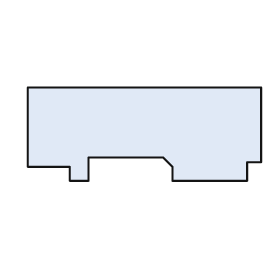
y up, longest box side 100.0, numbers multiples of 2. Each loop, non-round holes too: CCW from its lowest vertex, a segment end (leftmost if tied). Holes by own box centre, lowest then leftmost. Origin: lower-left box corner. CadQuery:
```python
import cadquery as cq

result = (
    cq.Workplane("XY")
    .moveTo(18.0, 0.0)
    .lineTo(26.0, 0.0)
    .lineTo(26.0, 10.0)
    .lineTo(58.0, 10.0)
    .lineTo(62.0, 6.0)
    .lineTo(62.0, 0.0)
    .lineTo(94.0, 0.0)
    .lineTo(94.0, 8.0)
    .lineTo(100.0, 8.0)
    .lineTo(100.0, 40.0)
    .lineTo(0.0, 40.0)
    .lineTo(0.0, 6.0)
    .lineTo(18.0, 6.0)
    .close()
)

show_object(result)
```